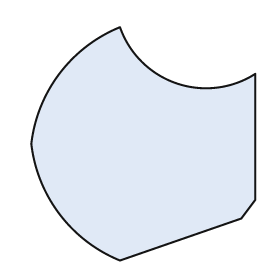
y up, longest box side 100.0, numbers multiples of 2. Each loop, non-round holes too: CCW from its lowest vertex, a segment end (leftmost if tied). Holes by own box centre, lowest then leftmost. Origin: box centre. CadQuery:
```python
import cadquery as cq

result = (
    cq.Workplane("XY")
    .moveTo(-10.0, -50.0)
    .lineTo(42.0, -32.0)
    .lineTo(48.0, -24.0)
    .lineTo(48.0, 30.0)
    .threePointArc((14.0, 26.0), (-10.0, 50.0))
    .threePointArc((-36.0, 30.0), (-48.0, 0.0))
    .threePointArc((-36.0, -30.0), (-10.0, -50.0))
    .close()
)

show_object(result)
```